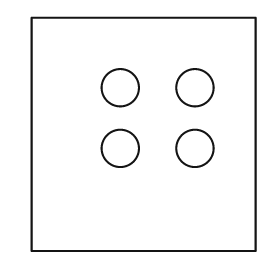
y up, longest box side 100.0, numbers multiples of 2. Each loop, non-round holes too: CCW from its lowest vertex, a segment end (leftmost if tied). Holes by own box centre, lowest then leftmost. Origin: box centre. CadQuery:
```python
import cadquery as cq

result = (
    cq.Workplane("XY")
    .moveTo(-48.0, -50.0)
    .lineTo(48.0, -50.0)
    .lineTo(48.0, 50.0)
    .lineTo(-48.0, 50.0)
    .close()
    .moveTo(-10.0, -6.0)
    .circle(8.0)
    .moveTo(22.0, -6.0)
    .circle(8.0)
    .moveTo(-10.0, 20.0)
    .circle(8.0)
    .moveTo(22.0, 20.0)
    .circle(8.0)
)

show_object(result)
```